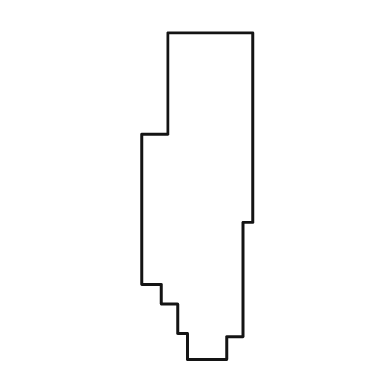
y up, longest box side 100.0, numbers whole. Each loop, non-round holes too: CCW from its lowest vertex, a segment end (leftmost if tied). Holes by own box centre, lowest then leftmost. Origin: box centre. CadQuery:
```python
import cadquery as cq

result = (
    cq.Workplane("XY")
    .moveTo(-3.0, -50.0)
    .lineTo(9.0, -50.0)
    .lineTo(9.0, -43.0)
    .lineTo(14.0, -43.0)
    .lineTo(14.0, -8.0)
    .lineTo(17.0, -8.0)
    .lineTo(17.0, 50.0)
    .lineTo(-9.0, 50.0)
    .lineTo(-9.0, 19.0)
    .lineTo(-17.0, 19.0)
    .lineTo(-17.0, -27.0)
    .lineTo(-11.0, -27.0)
    .lineTo(-11.0, -33.0)
    .lineTo(-6.0, -33.0)
    .lineTo(-6.0, -42.0)
    .lineTo(-3.0, -42.0)
    .close()
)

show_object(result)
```